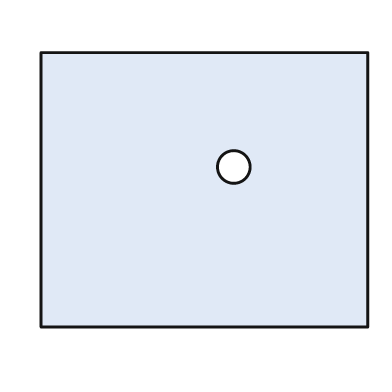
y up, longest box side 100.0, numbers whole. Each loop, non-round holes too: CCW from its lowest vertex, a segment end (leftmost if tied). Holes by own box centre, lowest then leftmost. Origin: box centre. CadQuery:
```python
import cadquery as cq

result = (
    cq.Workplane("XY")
    .moveTo(-50.0, -42.0)
    .lineTo(50.0, -42.0)
    .lineTo(50.0, 42.0)
    .lineTo(-50.0, 42.0)
    .close()
    .moveTo(9.0, 7.0)
    .circle(5.0)
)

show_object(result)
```